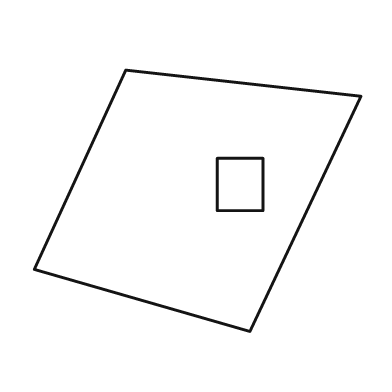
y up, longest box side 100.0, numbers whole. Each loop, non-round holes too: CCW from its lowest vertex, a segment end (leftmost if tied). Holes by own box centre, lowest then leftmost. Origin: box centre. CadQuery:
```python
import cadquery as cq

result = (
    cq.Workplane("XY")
    .moveTo(16.0, -40.0)
    .lineTo(50.0, 32.0)
    .lineTo(-22.0, 40.0)
    .lineTo(-50.0, -21.0)
    .close()
    .moveTo(6.0, -3.0)
    .lineTo(20.0, -3.0)
    .lineTo(20.0, 13.0)
    .lineTo(6.0, 13.0)
    .close()
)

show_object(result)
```